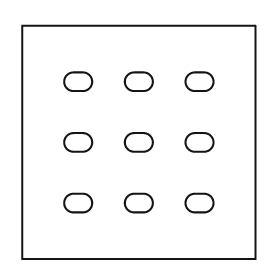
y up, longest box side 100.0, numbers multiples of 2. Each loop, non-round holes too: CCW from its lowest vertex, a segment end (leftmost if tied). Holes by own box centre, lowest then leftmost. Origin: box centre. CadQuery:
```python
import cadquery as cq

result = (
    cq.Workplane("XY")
    .moveTo(-50.0, -50.0)
    .lineTo(50.0, -50.0)
    .lineTo(50.0, 50.0)
    .lineTo(-50.0, 50.0)
    .close()
    .moveTo(-28.0, -30.0)
    .lineTo(-24.0, -30.0)
    .threePointArc((-20.0, -26.0), (-24.0, -22.0))
    .lineTo(-28.0, -22.0)
    .threePointArc((-32.0, -26.0), (-28.0, -30.0))
    .close()
    .moveTo(-2.0, -30.0)
    .lineTo(2.0, -30.0)
    .threePointArc((6.0, -26.0), (2.0, -22.0))
    .lineTo(-2.0, -22.0)
    .threePointArc((-6.0, -26.0), (-2.0, -30.0))
    .close()
    .moveTo(24.0, -30.0)
    .lineTo(28.0, -30.0)
    .threePointArc((32.0, -26.0), (28.0, -22.0))
    .lineTo(24.0, -22.0)
    .threePointArc((20.0, -26.0), (24.0, -30.0))
    .close()
    .moveTo(-28.0, -4.0)
    .lineTo(-24.0, -4.0)
    .threePointArc((-20.0, 0.0), (-24.0, 4.0))
    .lineTo(-28.0, 4.0)
    .threePointArc((-32.0, 0.0), (-28.0, -4.0))
    .close()
    .moveTo(-2.0, -4.0)
    .lineTo(2.0, -4.0)
    .threePointArc((6.0, 0.0), (2.0, 4.0))
    .lineTo(-2.0, 4.0)
    .threePointArc((-6.0, 0.0), (-2.0, -4.0))
    .close()
    .moveTo(24.0, -4.0)
    .lineTo(28.0, -4.0)
    .threePointArc((32.0, 0.0), (28.0, 4.0))
    .lineTo(24.0, 4.0)
    .threePointArc((20.0, 0.0), (24.0, -4.0))
    .close()
    .moveTo(-28.0, 22.0)
    .lineTo(-24.0, 22.0)
    .threePointArc((-20.0, 26.0), (-24.0, 30.0))
    .lineTo(-28.0, 30.0)
    .threePointArc((-32.0, 26.0), (-28.0, 22.0))
    .close()
    .moveTo(-2.0, 22.0)
    .lineTo(2.0, 22.0)
    .threePointArc((6.0, 26.0), (2.0, 30.0))
    .lineTo(-2.0, 30.0)
    .threePointArc((-6.0, 26.0), (-2.0, 22.0))
    .close()
    .moveTo(24.0, 22.0)
    .lineTo(28.0, 22.0)
    .threePointArc((32.0, 26.0), (28.0, 30.0))
    .lineTo(24.0, 30.0)
    .threePointArc((20.0, 26.0), (24.0, 22.0))
    .close()
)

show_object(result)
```